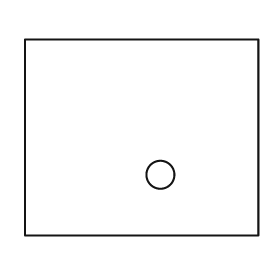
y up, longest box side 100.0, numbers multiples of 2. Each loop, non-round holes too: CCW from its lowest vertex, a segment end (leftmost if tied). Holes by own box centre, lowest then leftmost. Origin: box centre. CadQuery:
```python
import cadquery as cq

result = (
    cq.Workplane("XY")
    .moveTo(-50.0, -42.0)
    .lineTo(50.0, -42.0)
    .lineTo(50.0, 42.0)
    .lineTo(-50.0, 42.0)
    .close()
    .moveTo(8.0, -16.0)
    .circle(6.0)
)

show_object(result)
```